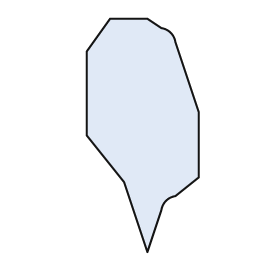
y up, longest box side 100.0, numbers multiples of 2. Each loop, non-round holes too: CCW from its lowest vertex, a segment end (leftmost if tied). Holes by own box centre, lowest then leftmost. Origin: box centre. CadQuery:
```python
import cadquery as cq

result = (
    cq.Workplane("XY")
    .moveTo(2.0, -50.0)
    .lineTo(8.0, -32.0)
    .threePointArc((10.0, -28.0), (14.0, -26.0))
    .lineTo(24.0, -18.0)
    .lineTo(24.0, 10.0)
    .lineTo(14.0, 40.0)
    .threePointArc((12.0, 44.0), (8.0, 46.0))
    .lineTo(2.0, 50.0)
    .lineTo(-14.0, 50.0)
    .lineTo(-24.0, 36.0)
    .lineTo(-24.0, 0.0)
    .lineTo(-8.0, -20.0)
    .close()
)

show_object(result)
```